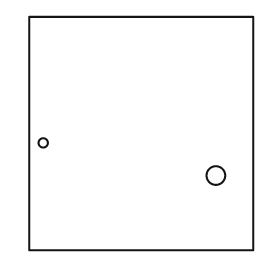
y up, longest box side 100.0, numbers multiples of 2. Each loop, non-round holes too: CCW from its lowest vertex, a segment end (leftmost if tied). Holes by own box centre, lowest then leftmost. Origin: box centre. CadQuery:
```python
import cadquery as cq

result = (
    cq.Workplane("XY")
    .moveTo(-48.0, -50.0)
    .lineTo(48.0, -50.0)
    .lineTo(48.0, 50.0)
    .lineTo(-48.0, 50.0)
    .close()
    .moveTo(32.0, -18.0)
    .circle(4.0)
    .moveTo(-42.0, -4.0)
    .circle(2.0)
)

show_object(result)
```